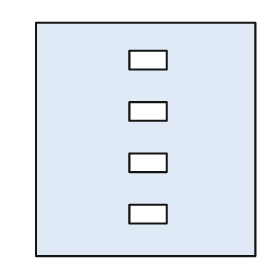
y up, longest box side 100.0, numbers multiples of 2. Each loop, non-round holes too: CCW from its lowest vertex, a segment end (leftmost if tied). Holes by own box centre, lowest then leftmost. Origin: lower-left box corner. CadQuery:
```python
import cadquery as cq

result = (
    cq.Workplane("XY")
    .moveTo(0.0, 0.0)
    .lineTo(94.0, 0.0)
    .lineTo(94.0, 100.0)
    .lineTo(0.0, 100.0)
    .close()
    .moveTo(40.0, 14.0)
    .lineTo(56.0, 14.0)
    .lineTo(56.0, 22.0)
    .lineTo(40.0, 22.0)
    .close()
    .moveTo(40.0, 36.0)
    .lineTo(56.0, 36.0)
    .lineTo(56.0, 44.0)
    .lineTo(40.0, 44.0)
    .close()
    .moveTo(40.0, 58.0)
    .lineTo(56.0, 58.0)
    .lineTo(56.0, 66.0)
    .lineTo(40.0, 66.0)
    .close()
    .moveTo(40.0, 80.0)
    .lineTo(56.0, 80.0)
    .lineTo(56.0, 88.0)
    .lineTo(40.0, 88.0)
    .close()
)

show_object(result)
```